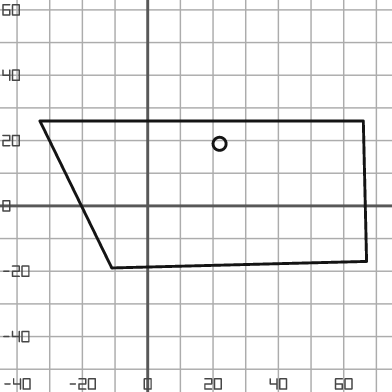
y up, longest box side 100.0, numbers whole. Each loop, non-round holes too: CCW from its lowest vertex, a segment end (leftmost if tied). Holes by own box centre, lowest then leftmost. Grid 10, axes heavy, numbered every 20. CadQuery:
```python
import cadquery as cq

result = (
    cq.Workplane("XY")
    .moveTo(-11.0, -19.0)
    .lineTo(67.0, -17.0)
    .lineTo(66.0, 26.0)
    .lineTo(-33.0, 26.0)
    .close()
    .moveTo(22.0, 19.0)
    .circle(2.0)
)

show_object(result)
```